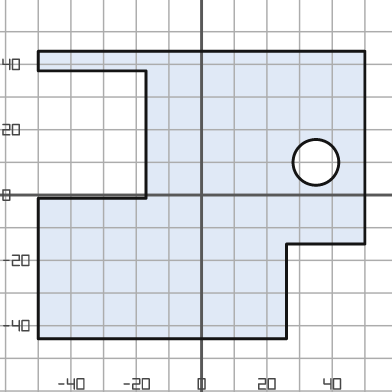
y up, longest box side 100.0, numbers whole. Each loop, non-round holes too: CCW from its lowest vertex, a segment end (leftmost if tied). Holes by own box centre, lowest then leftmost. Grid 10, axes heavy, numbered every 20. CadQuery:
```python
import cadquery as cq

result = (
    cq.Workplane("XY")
    .moveTo(-50.0, -44.0)
    .lineTo(26.0, -44.0)
    .lineTo(26.0, -15.0)
    .lineTo(50.0, -15.0)
    .lineTo(50.0, 44.0)
    .lineTo(-50.0, 44.0)
    .lineTo(-50.0, 38.0)
    .lineTo(-17.0, 38.0)
    .lineTo(-17.0, -1.0)
    .lineTo(-50.0, -1.0)
    .close()
    .moveTo(35.0, 10.0)
    .circle(7.0)
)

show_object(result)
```